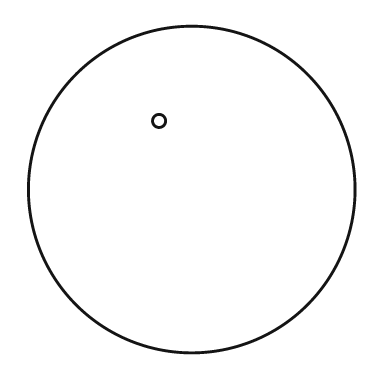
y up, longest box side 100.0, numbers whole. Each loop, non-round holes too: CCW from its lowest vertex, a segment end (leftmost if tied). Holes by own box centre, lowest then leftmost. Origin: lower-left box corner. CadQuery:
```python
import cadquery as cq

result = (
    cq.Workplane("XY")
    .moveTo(50.0, 50.0)
    .circle(50.0)
    .moveTo(40.0, 71.0)
    .circle(2.0)
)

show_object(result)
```